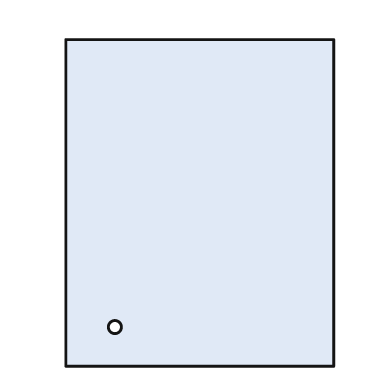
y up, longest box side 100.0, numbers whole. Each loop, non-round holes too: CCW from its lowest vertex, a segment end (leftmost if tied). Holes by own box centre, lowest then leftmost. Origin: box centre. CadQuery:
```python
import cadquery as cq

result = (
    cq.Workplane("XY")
    .moveTo(-41.0, -50.0)
    .lineTo(41.0, -50.0)
    .lineTo(41.0, 50.0)
    .lineTo(-41.0, 50.0)
    .close()
    .moveTo(-26.0, -38.0)
    .circle(2.0)
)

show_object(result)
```